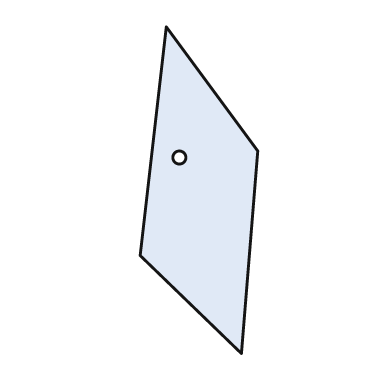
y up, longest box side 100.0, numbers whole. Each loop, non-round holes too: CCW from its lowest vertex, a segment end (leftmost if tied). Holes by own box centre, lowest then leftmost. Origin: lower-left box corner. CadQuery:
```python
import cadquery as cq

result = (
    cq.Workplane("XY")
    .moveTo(31.0, 0.0)
    .lineTo(36.0, 62.0)
    .lineTo(8.0, 100.0)
    .lineTo(0.0, 30.0)
    .close()
    .moveTo(12.0, 60.0)
    .circle(2.0)
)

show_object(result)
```